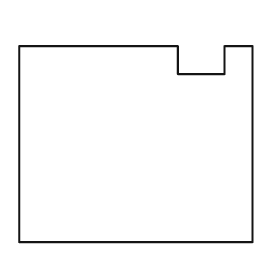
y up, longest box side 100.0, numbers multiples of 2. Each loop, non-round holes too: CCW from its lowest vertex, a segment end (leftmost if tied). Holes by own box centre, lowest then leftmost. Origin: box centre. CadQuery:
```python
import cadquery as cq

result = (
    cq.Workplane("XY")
    .moveTo(-50.0, -42.0)
    .lineTo(50.0, -42.0)
    .lineTo(50.0, 42.0)
    .lineTo(38.0, 42.0)
    .lineTo(38.0, 30.0)
    .lineTo(18.0, 30.0)
    .lineTo(18.0, 42.0)
    .lineTo(-50.0, 42.0)
    .close()
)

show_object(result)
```